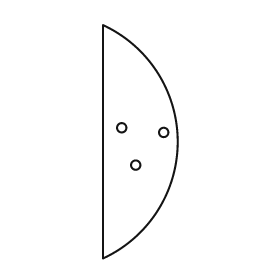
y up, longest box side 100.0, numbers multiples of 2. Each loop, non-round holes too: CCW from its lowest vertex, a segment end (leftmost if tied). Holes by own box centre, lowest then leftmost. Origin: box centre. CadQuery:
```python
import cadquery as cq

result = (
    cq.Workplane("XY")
    .moveTo(-16.0, -50.0)
    .threePointArc((16.0, 0.0), (-16.0, 50.0))
    .close()
    .moveTo(-2.0, -10.0)
    .circle(2.0)
    .moveTo(10.0, 4.0)
    .circle(2.0)
    .moveTo(-8.0, 6.0)
    .circle(2.0)
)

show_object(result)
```